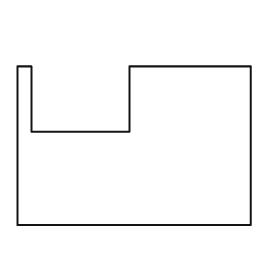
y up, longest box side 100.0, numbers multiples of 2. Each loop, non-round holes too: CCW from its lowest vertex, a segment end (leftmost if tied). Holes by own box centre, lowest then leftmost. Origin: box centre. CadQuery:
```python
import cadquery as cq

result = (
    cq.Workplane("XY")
    .moveTo(-50.0, -34.0)
    .lineTo(50.0, -34.0)
    .lineTo(50.0, 34.0)
    .lineTo(-2.0, 34.0)
    .lineTo(-2.0, 6.0)
    .lineTo(-44.0, 6.0)
    .lineTo(-44.0, 34.0)
    .lineTo(-50.0, 34.0)
    .close()
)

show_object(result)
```